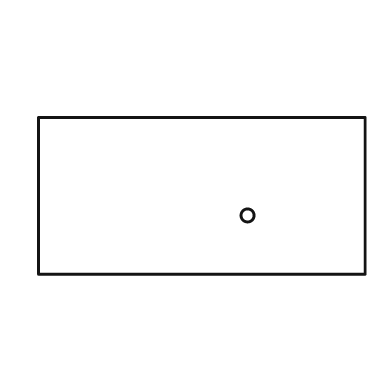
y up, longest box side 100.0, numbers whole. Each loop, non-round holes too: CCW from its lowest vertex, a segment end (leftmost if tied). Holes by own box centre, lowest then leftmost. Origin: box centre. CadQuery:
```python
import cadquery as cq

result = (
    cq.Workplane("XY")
    .moveTo(-50.0, -24.0)
    .lineTo(50.0, -24.0)
    .lineTo(50.0, 24.0)
    .lineTo(-50.0, 24.0)
    .close()
    .moveTo(14.0, -6.0)
    .circle(2.0)
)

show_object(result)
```